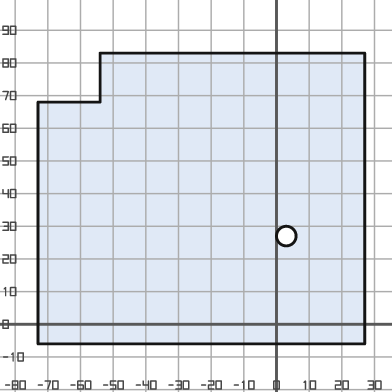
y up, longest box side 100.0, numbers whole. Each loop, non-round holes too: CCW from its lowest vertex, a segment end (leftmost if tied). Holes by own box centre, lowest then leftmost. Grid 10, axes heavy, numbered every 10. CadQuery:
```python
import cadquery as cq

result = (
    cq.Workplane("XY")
    .moveTo(-73.0, -6.0)
    .lineTo(27.0, -6.0)
    .lineTo(27.0, 83.0)
    .lineTo(-54.0, 83.0)
    .lineTo(-54.0, 68.0)
    .lineTo(-73.0, 68.0)
    .close()
    .moveTo(3.0, 27.0)
    .circle(3.0)
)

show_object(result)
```